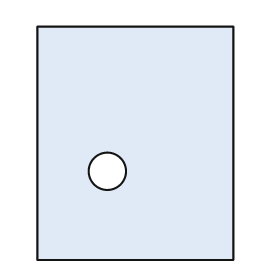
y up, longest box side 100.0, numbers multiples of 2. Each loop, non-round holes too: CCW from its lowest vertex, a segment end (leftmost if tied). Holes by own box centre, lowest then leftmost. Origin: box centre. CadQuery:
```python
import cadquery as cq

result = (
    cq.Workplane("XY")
    .moveTo(-42.0, -50.0)
    .lineTo(42.0, -50.0)
    .lineTo(42.0, 50.0)
    .lineTo(-42.0, 50.0)
    .close()
    .moveTo(-12.0, -12.0)
    .circle(8.0)
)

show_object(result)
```